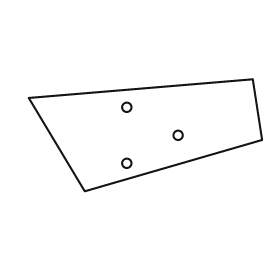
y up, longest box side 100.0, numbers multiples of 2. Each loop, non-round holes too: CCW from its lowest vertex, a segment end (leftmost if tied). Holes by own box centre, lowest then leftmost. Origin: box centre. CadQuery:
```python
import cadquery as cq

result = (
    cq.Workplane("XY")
    .moveTo(-26.0, -24.0)
    .lineTo(50.0, -2.0)
    .lineTo(46.0, 24.0)
    .lineTo(-50.0, 16.0)
    .close()
    .moveTo(-8.0, -12.0)
    .circle(2.0)
    .moveTo(14.0, 0.0)
    .circle(2.0)
    .moveTo(-8.0, 12.0)
    .circle(2.0)
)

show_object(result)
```